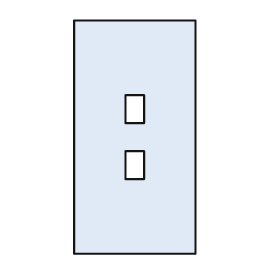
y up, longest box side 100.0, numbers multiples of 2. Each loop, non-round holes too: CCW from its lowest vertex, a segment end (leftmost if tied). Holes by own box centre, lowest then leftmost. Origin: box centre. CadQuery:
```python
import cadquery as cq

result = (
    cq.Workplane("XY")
    .moveTo(-26.0, -50.0)
    .lineTo(26.0, -50.0)
    .lineTo(26.0, 50.0)
    .lineTo(-26.0, 50.0)
    .close()
    .moveTo(-4.0, -18.0)
    .lineTo(4.0, -18.0)
    .lineTo(4.0, -6.0)
    .lineTo(-4.0, -6.0)
    .close()
    .moveTo(-4.0, 6.0)
    .lineTo(4.0, 6.0)
    .lineTo(4.0, 18.0)
    .lineTo(-4.0, 18.0)
    .close()
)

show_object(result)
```